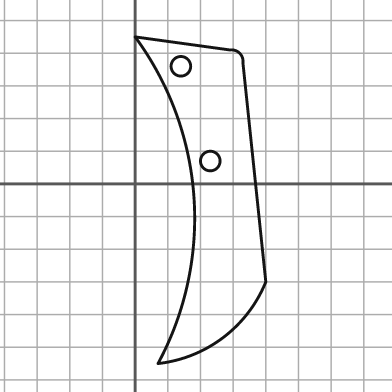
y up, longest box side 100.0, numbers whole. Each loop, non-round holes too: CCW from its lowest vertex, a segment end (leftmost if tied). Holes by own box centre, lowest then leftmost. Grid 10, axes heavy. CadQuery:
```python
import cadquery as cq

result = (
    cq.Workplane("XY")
    .moveTo(7.0, -55.0)
    .threePointArc((27.0, -47.0), (40.0, -30.0))
    .lineTo(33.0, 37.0)
    .threePointArc((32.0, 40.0), (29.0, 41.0))
    .lineTo(0.0, 45.0)
    .threePointArc((18.0, -4.0), (7.0, -55.0))
    .close()
    .moveTo(23.0, 7.0)
    .circle(3.0)
    .moveTo(14.0, 36.0)
    .circle(3.0)
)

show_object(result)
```